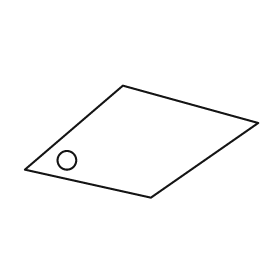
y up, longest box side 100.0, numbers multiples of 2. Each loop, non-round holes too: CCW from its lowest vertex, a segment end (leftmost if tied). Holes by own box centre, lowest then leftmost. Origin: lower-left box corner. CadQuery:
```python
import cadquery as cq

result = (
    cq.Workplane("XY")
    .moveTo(54.0, 0.0)
    .lineTo(100.0, 32.0)
    .lineTo(42.0, 48.0)
    .lineTo(0.0, 12.0)
    .close()
    .moveTo(18.0, 16.0)
    .circle(4.0)
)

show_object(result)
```